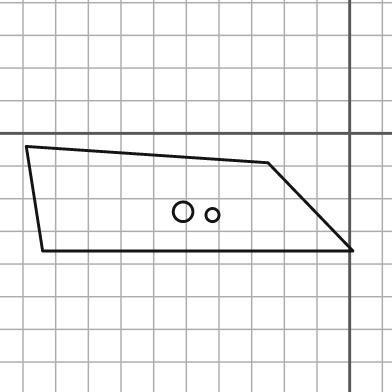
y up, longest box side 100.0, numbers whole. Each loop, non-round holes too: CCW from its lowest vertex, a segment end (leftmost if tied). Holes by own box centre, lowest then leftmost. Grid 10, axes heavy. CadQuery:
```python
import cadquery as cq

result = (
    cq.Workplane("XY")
    .moveTo(-94.0, -36.0)
    .lineTo(1.0, -36.0)
    .lineTo(-25.0, -9.0)
    .lineTo(-99.0, -4.0)
    .close()
    .moveTo(-42.0, -25.0)
    .circle(2.0)
    .moveTo(-51.0, -24.0)
    .circle(3.0)
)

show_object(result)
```